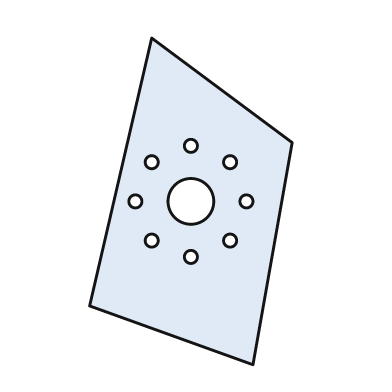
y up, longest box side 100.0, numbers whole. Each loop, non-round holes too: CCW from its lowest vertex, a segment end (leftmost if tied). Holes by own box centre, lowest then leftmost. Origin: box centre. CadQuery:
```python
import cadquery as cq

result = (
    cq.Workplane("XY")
    .moveTo(19.0, -50.0)
    .lineTo(31.0, 18.0)
    .lineTo(-12.0, 50.0)
    .lineTo(-31.0, -32.0)
    .close()
    .moveTo(0.0, -17.0)
    .circle(2.0)
    .moveTo(-12.0, -12.0)
    .circle(2.0)
    .moveTo(12.0, -12.0)
    .circle(2.0)
    .moveTo(-17.0, 0.0)
    .circle(2.0)
    .moveTo(0.0, 0.0)
    .circle(7.0)
    .moveTo(17.0, 0.0)
    .circle(2.0)
    .moveTo(-12.0, 12.0)
    .circle(2.0)
    .moveTo(12.0, 12.0)
    .circle(2.0)
    .moveTo(0.0, 17.0)
    .circle(2.0)
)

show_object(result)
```